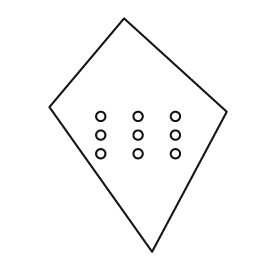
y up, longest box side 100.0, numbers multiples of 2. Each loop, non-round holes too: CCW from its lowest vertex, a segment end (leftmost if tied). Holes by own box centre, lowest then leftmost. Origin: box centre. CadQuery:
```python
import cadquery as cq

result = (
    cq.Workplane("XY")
    .moveTo(6.0, -50.0)
    .lineTo(38.0, 10.0)
    .lineTo(-6.0, 50.0)
    .lineTo(-38.0, 12.0)
    .close()
    .moveTo(-16.0, -8.0)
    .circle(2.0)
    .moveTo(0.0, -8.0)
    .circle(2.0)
    .moveTo(16.0, -8.0)
    .circle(2.0)
    .moveTo(-16.0, 0.0)
    .circle(2.0)
    .moveTo(0.0, 0.0)
    .circle(2.0)
    .moveTo(16.0, 0.0)
    .circle(2.0)
    .moveTo(-16.0, 8.0)
    .circle(2.0)
    .moveTo(0.0, 8.0)
    .circle(2.0)
    .moveTo(16.0, 8.0)
    .circle(2.0)
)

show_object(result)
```